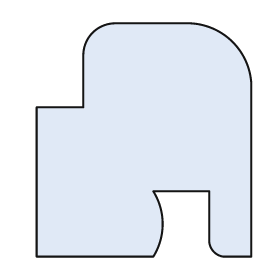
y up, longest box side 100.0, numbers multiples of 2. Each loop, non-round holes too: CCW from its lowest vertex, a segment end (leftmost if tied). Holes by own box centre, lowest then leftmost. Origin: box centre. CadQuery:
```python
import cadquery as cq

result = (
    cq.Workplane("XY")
    .moveTo(-46.0, -50.0)
    .lineTo(4.0, -50.0)
    .threePointArc((8.0, -36.0), (4.0, -22.0))
    .lineTo(28.0, -22.0)
    .lineTo(28.0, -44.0)
    .threePointArc((30.0, -48.0), (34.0, -50.0))
    .lineTo(46.0, -50.0)
    .lineTo(46.0, 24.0)
    .threePointArc((38.0, 42.0), (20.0, 50.0))
    .lineTo(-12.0, 50.0)
    .threePointArc((-22.0, 46.0), (-26.0, 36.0))
    .lineTo(-26.0, 14.0)
    .lineTo(-46.0, 14.0)
    .close()
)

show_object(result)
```